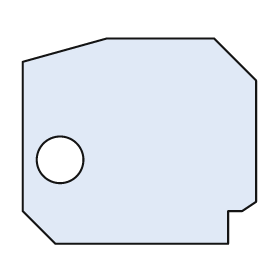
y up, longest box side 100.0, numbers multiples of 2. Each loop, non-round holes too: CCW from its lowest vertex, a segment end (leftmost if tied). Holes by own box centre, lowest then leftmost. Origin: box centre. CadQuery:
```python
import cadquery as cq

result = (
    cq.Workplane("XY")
    .moveTo(-36.0, -44.0)
    .lineTo(38.0, -44.0)
    .lineTo(38.0, -30.0)
    .lineTo(44.0, -30.0)
    .lineTo(50.0, -26.0)
    .lineTo(50.0, 26.0)
    .lineTo(32.0, 44.0)
    .lineTo(-14.0, 44.0)
    .lineTo(-50.0, 34.0)
    .lineTo(-50.0, -30.0)
    .close()
    .moveTo(-34.0, -8.0)
    .circle(10.0)
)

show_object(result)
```